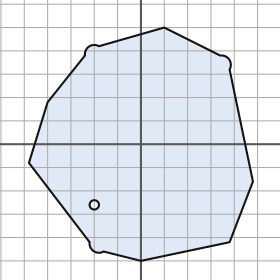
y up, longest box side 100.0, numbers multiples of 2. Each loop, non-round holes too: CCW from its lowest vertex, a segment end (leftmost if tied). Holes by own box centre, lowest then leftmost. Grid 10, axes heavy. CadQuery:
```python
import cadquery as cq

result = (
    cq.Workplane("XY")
    .moveTo(0.0, -50.0)
    .lineTo(38.0, -42.0)
    .lineTo(48.0, -16.0)
    .lineTo(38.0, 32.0)
    .threePointArc((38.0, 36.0), (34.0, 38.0))
    .lineTo(10.0, 50.0)
    .lineTo(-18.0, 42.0)
    .threePointArc((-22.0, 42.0), (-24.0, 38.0))
    .lineTo(-40.0, 18.0)
    .lineTo(-48.0, -8.0)
    .lineTo(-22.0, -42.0)
    .threePointArc((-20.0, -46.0), (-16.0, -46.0))
    .close()
    .moveTo(-20.0, -26.0)
    .circle(2.0)
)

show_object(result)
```